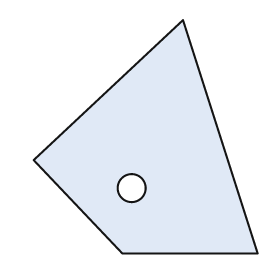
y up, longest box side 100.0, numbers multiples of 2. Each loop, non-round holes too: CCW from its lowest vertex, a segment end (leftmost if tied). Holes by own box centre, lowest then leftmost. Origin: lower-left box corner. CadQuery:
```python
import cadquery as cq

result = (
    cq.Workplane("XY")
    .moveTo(38.0, 0.0)
    .lineTo(96.0, 0.0)
    .lineTo(64.0, 100.0)
    .lineTo(0.0, 40.0)
    .close()
    .moveTo(42.0, 28.0)
    .circle(6.0)
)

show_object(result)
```